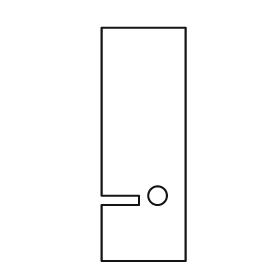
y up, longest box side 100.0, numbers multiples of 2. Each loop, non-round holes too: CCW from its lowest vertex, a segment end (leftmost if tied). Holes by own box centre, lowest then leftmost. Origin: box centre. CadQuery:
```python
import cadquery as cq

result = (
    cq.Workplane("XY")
    .moveTo(-18.0, -50.0)
    .lineTo(18.0, -50.0)
    .lineTo(18.0, 50.0)
    .lineTo(-18.0, 50.0)
    .lineTo(-18.0, -22.0)
    .lineTo(-2.0, -22.0)
    .lineTo(-2.0, -26.0)
    .lineTo(-18.0, -26.0)
    .close()
    .moveTo(6.0, -22.0)
    .circle(4.0)
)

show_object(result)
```